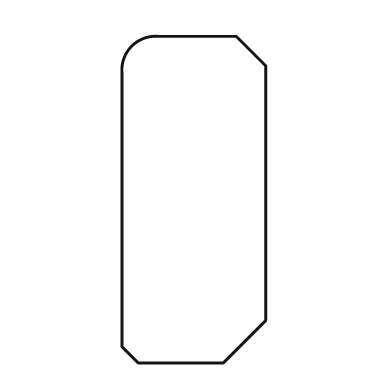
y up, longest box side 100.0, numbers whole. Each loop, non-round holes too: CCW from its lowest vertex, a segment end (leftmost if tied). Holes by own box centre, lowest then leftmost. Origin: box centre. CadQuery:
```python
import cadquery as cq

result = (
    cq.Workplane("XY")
    .moveTo(-17.0, -50.0)
    .lineTo(9.0, -50.0)
    .lineTo(22.0, -37.0)
    .lineTo(22.0, 41.0)
    .lineTo(13.0, 50.0)
    .lineTo(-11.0, 50.0)
    .threePointArc((-19.0, 47.0), (-22.0, 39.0))
    .lineTo(-22.0, -45.0)
    .close()
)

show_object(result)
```